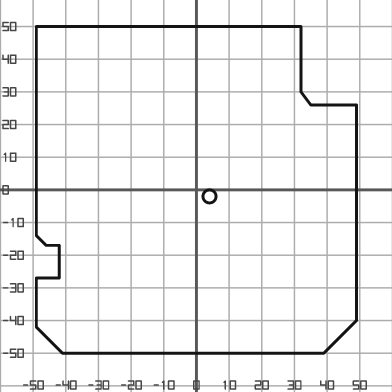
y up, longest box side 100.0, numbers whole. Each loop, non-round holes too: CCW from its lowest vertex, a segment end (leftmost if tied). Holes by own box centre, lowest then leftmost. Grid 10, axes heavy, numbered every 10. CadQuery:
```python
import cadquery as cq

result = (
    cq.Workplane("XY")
    .moveTo(-41.0, -50.0)
    .lineTo(39.0, -50.0)
    .lineTo(49.0, -40.0)
    .lineTo(49.0, 26.0)
    .lineTo(35.0, 26.0)
    .lineTo(32.0, 30.0)
    .lineTo(32.0, 50.0)
    .lineTo(-49.0, 50.0)
    .lineTo(-49.0, -14.0)
    .lineTo(-46.0, -17.0)
    .lineTo(-42.0, -17.0)
    .lineTo(-42.0, -27.0)
    .lineTo(-49.0, -27.0)
    .lineTo(-49.0, -42.0)
    .close()
    .moveTo(4.0, -2.0)
    .circle(2.0)
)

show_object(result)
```